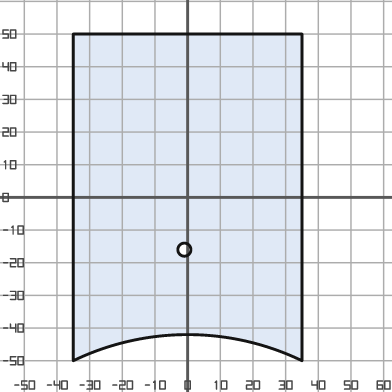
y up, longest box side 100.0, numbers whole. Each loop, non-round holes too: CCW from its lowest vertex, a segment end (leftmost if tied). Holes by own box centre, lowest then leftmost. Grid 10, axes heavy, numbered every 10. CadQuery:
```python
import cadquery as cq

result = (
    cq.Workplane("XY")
    .moveTo(-35.0, -50.0)
    .threePointArc((0.0, -42.0), (35.0, -50.0))
    .lineTo(35.0, 50.0)
    .lineTo(-35.0, 50.0)
    .close()
    .moveTo(-1.0, -16.0)
    .circle(2.0)
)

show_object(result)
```